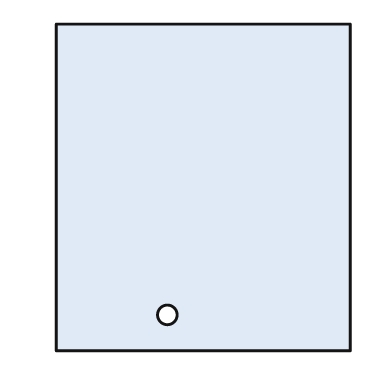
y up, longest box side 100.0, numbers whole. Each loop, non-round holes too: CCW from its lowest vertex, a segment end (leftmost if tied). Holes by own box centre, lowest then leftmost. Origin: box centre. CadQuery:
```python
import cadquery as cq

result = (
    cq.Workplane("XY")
    .moveTo(-45.0, -50.0)
    .lineTo(45.0, -50.0)
    .lineTo(45.0, 50.0)
    .lineTo(-45.0, 50.0)
    .close()
    .moveTo(-11.0, -39.0)
    .circle(3.0)
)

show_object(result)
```